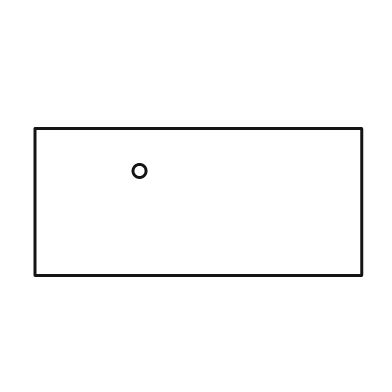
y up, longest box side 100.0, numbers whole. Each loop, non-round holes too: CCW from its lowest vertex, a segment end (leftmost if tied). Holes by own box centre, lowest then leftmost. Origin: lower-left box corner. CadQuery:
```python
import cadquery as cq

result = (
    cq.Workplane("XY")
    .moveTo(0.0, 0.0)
    .lineTo(100.0, 0.0)
    .lineTo(100.0, 45.0)
    .lineTo(0.0, 45.0)
    .close()
    .moveTo(32.0, 32.0)
    .circle(2.0)
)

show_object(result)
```